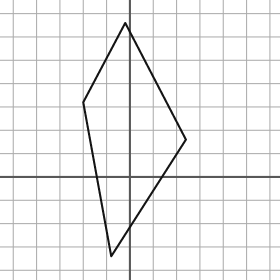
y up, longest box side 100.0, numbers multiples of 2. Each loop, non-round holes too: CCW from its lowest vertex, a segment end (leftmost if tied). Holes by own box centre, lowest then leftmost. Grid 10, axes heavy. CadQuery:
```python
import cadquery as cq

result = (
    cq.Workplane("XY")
    .moveTo(-8.0, -34.0)
    .lineTo(24.0, 16.0)
    .lineTo(-2.0, 66.0)
    .lineTo(-20.0, 32.0)
    .close()
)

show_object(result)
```